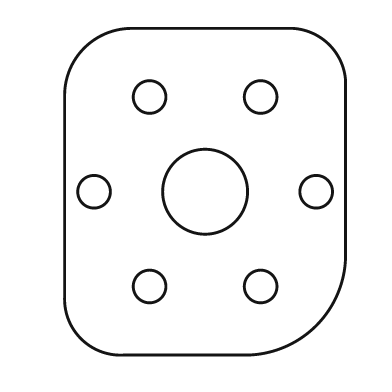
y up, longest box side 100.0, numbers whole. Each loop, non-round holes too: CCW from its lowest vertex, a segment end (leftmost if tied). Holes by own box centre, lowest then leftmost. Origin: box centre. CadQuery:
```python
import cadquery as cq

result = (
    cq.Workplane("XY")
    .moveTo(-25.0, -50.0)
    .lineTo(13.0, -50.0)
    .threePointArc((34.0, -41.0), (43.0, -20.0))
    .lineTo(43.0, 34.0)
    .threePointArc((38.0, 45.0), (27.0, 50.0))
    .lineTo(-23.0, 50.0)
    .threePointArc((-37.0, 44.0), (-43.0, 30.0))
    .lineTo(-43.0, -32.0)
    .threePointArc((-38.0, -45.0), (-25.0, -50.0))
    .close()
    .moveTo(-17.0, -29.0)
    .circle(5.0)
    .moveTo(17.0, -29.0)
    .circle(5.0)
    .moveTo(-34.0, 0.0)
    .circle(5.0)
    .moveTo(0.0, 0.0)
    .circle(13.0)
    .moveTo(34.0, 0.0)
    .circle(5.0)
    .moveTo(-17.0, 29.0)
    .circle(5.0)
    .moveTo(17.0, 29.0)
    .circle(5.0)
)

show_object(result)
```